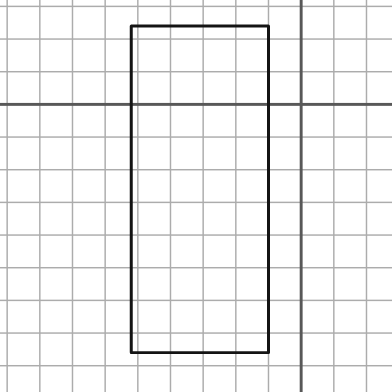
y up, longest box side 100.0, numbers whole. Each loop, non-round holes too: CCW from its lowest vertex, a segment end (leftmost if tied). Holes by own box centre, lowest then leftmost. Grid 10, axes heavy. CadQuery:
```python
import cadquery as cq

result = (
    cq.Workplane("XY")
    .moveTo(-52.0, -76.0)
    .lineTo(-10.0, -76.0)
    .lineTo(-10.0, 24.0)
    .lineTo(-52.0, 24.0)
    .close()
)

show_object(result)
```